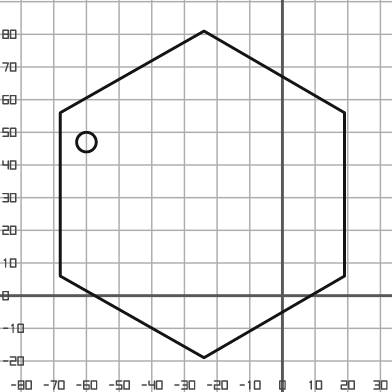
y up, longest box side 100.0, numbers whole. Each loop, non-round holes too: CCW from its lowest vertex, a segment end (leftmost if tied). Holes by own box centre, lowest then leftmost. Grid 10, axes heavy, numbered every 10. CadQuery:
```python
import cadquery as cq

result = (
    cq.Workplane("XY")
    .moveTo(-24.0, -19.0)
    .lineTo(19.0, 6.0)
    .lineTo(19.0, 56.0)
    .lineTo(-24.0, 81.0)
    .lineTo(-68.0, 56.0)
    .lineTo(-68.0, 6.0)
    .close()
    .moveTo(-60.0, 47.0)
    .circle(3.0)
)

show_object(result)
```